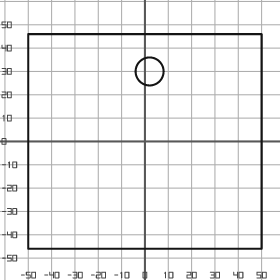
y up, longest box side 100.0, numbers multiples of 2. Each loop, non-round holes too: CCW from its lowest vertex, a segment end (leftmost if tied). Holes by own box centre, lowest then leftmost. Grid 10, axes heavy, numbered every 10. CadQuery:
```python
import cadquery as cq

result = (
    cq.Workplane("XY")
    .moveTo(-50.0, -46.0)
    .lineTo(50.0, -46.0)
    .lineTo(50.0, 46.0)
    .lineTo(-50.0, 46.0)
    .close()
    .moveTo(2.0, 30.0)
    .circle(6.0)
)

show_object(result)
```